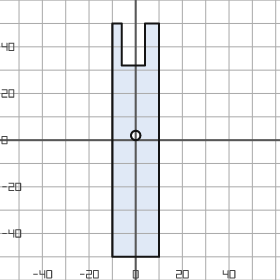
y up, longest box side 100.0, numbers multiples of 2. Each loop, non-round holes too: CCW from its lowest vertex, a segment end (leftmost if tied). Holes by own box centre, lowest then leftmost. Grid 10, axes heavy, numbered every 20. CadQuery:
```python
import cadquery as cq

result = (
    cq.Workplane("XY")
    .moveTo(-10.0, -50.0)
    .lineTo(10.0, -50.0)
    .lineTo(10.0, 50.0)
    .lineTo(4.0, 50.0)
    .lineTo(4.0, 32.0)
    .lineTo(-6.0, 32.0)
    .lineTo(-6.0, 50.0)
    .lineTo(-10.0, 50.0)
    .close()
    .moveTo(0.0, 2.0)
    .circle(2.0)
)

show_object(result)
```